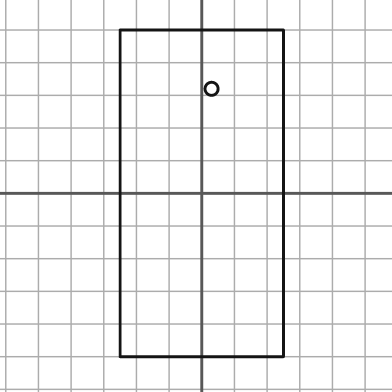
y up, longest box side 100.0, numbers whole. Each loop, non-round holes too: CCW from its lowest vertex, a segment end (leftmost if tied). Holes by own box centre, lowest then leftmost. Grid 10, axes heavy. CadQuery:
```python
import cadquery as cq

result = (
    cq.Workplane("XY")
    .moveTo(-25.0, -50.0)
    .lineTo(25.0, -50.0)
    .lineTo(25.0, 50.0)
    .lineTo(-25.0, 50.0)
    .close()
    .moveTo(3.0, 32.0)
    .circle(2.0)
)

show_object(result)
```